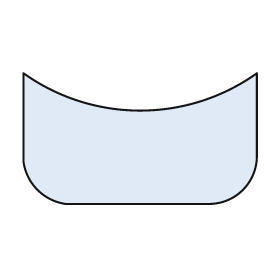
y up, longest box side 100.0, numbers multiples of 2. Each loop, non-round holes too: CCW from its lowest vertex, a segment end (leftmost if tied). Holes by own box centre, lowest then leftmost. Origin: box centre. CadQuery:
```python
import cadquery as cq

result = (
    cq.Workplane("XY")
    .moveTo(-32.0, -28.0)
    .lineTo(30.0, -28.0)
    .threePointArc((44.0, -22.0), (50.0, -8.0))
    .lineTo(50.0, 28.0)
    .threePointArc((0.0, 12.0), (-50.0, 28.0))
    .lineTo(-50.0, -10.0)
    .threePointArc((-44.0, -22.0), (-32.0, -28.0))
    .close()
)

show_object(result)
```